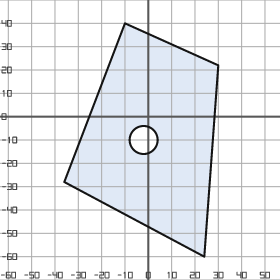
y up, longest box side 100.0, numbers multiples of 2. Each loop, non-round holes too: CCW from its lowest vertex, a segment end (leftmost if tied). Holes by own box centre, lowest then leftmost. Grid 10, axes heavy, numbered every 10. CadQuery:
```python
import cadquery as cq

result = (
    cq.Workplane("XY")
    .moveTo(24.0, -60.0)
    .lineTo(30.0, 22.0)
    .lineTo(-10.0, 40.0)
    .lineTo(-36.0, -28.0)
    .close()
    .moveTo(-2.0, -10.0)
    .circle(6.0)
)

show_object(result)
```